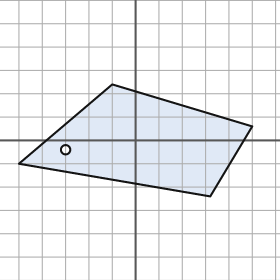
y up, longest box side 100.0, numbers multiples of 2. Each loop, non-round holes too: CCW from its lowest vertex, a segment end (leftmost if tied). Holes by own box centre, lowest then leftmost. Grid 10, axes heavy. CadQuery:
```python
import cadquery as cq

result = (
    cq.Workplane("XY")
    .moveTo(32.0, -24.0)
    .lineTo(50.0, 6.0)
    .lineTo(-10.0, 24.0)
    .lineTo(-50.0, -10.0)
    .close()
    .moveTo(-30.0, -4.0)
    .circle(2.0)
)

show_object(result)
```